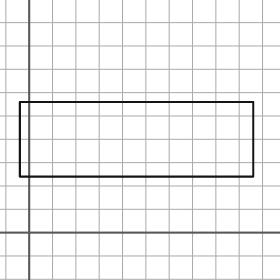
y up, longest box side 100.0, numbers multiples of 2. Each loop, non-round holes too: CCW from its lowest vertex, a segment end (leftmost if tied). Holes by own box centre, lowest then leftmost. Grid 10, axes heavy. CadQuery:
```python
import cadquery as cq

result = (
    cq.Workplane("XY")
    .moveTo(-4.0, 24.0)
    .lineTo(96.0, 24.0)
    .lineTo(96.0, 56.0)
    .lineTo(-4.0, 56.0)
    .close()
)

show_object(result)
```